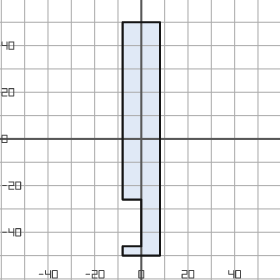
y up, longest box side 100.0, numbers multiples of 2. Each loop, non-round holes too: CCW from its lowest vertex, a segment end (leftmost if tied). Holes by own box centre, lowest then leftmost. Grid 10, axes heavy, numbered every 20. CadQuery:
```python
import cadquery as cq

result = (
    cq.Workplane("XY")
    .moveTo(-8.0, -50.0)
    .lineTo(8.0, -50.0)
    .lineTo(8.0, 50.0)
    .lineTo(-8.0, 50.0)
    .lineTo(-8.0, -26.0)
    .lineTo(0.0, -26.0)
    .lineTo(0.0, -46.0)
    .lineTo(-8.0, -46.0)
    .close()
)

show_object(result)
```